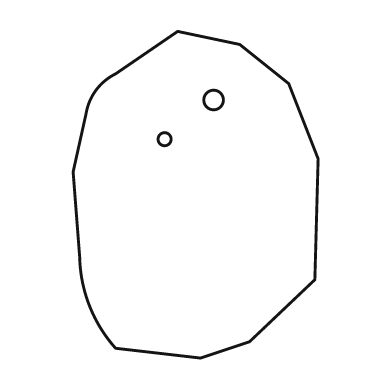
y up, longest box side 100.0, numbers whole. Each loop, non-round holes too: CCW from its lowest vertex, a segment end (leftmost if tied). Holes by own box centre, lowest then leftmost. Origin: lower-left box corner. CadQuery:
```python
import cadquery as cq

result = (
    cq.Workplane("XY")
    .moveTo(39.0, 0.0)
    .lineTo(54.0, 5.0)
    .lineTo(74.0, 24.0)
    .lineTo(75.0, 61.0)
    .lineTo(66.0, 84.0)
    .lineTo(51.0, 96.0)
    .lineTo(32.0, 100.0)
    .lineTo(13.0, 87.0)
    .threePointArc((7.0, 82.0), (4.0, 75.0))
    .lineTo(0.0, 57.0)
    .lineTo(2.0, 31.0)
    .threePointArc((5.0, 16.0), (13.0, 3.0))
    .close()
    .moveTo(28.0, 67.0)
    .circle(2.0)
    .moveTo(43.0, 79.0)
    .circle(3.0)
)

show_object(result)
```